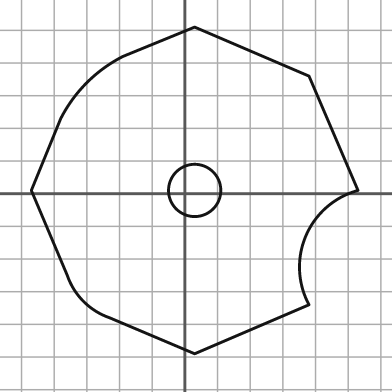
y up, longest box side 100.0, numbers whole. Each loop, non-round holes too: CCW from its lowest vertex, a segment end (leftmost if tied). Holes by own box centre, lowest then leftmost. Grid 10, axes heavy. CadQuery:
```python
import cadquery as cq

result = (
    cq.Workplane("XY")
    .moveTo(3.0, -49.0)
    .lineTo(38.0, -34.0)
    .threePointArc((37.0, -13.0), (53.0, 1.0))
    .lineTo(38.0, 36.0)
    .lineTo(3.0, 51.0)
    .lineTo(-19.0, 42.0)
    .threePointArc((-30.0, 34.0), (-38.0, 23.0))
    .lineTo(-47.0, 1.0)
    .lineTo(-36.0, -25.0)
    .threePointArc((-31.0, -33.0), (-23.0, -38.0))
    .close()
    .moveTo(3.0, 1.0)
    .circle(8.0)
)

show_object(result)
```